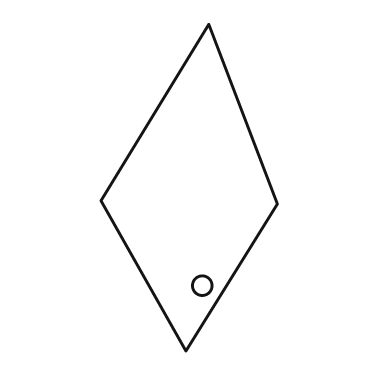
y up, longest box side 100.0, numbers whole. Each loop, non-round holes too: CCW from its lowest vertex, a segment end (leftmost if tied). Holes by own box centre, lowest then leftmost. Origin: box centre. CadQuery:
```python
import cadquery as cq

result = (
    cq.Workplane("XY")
    .moveTo(-1.0, -50.0)
    .lineTo(27.0, -5.0)
    .lineTo(6.0, 50.0)
    .lineTo(-27.0, -4.0)
    .close()
    .moveTo(4.0, -30.0)
    .circle(3.0)
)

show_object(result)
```